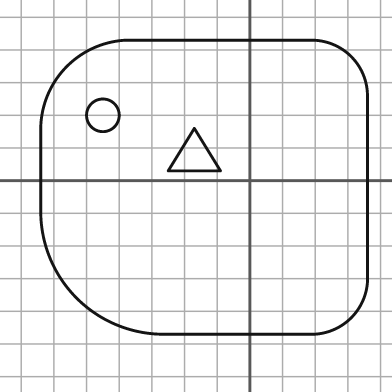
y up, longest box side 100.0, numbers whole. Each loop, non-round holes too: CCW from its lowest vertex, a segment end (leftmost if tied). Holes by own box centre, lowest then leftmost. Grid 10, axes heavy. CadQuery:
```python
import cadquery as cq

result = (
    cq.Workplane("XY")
    .moveTo(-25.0, -47.0)
    .lineTo(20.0, -47.0)
    .threePointArc((31.0, -42.0), (36.0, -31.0))
    .lineTo(36.0, 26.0)
    .threePointArc((31.0, 38.0), (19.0, 43.0))
    .lineTo(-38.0, 43.0)
    .threePointArc((-56.0, 35.0), (-64.0, 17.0))
    .lineTo(-64.0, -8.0)
    .threePointArc((-53.0, -36.0), (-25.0, -47.0))
    .close()
    .moveTo(-25.0, 3.0)
    .lineTo(-9.0, 3.0)
    .lineTo(-17.0, 16.0)
    .close()
    .moveTo(-45.0, 20.0)
    .circle(5.0)
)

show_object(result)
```